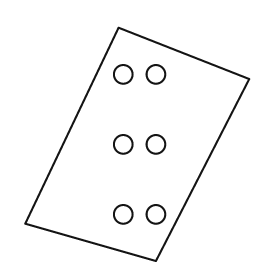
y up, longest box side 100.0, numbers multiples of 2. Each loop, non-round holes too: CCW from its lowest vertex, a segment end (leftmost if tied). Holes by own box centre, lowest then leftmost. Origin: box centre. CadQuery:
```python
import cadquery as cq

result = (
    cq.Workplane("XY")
    .moveTo(8.0, -50.0)
    .lineTo(48.0, 28.0)
    .lineTo(-8.0, 50.0)
    .lineTo(-48.0, -34.0)
    .close()
    .moveTo(-6.0, -30.0)
    .circle(4.0)
    .moveTo(8.0, -30.0)
    .circle(4.0)
    .moveTo(-6.0, 0.0)
    .circle(4.0)
    .moveTo(8.0, 0.0)
    .circle(4.0)
    .moveTo(-6.0, 30.0)
    .circle(4.0)
    .moveTo(8.0, 30.0)
    .circle(4.0)
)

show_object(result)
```